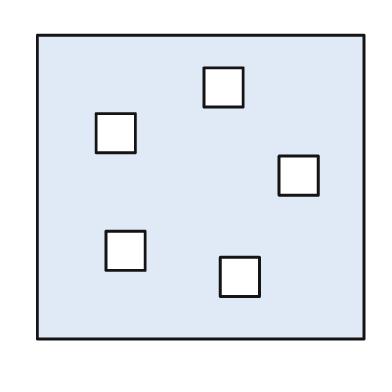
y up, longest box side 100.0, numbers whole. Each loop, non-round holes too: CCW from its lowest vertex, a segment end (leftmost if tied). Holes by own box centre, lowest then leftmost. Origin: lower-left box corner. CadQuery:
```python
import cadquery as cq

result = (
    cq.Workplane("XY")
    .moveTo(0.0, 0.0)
    .lineTo(100.0, 0.0)
    .lineTo(100.0, 93.0)
    .lineTo(0.0, 93.0)
    .close()
    .moveTo(56.0, 13.0)
    .lineTo(68.0, 13.0)
    .lineTo(68.0, 25.0)
    .lineTo(56.0, 25.0)
    .close()
    .moveTo(21.0, 21.0)
    .lineTo(33.0, 21.0)
    .lineTo(33.0, 33.0)
    .lineTo(21.0, 33.0)
    .close()
    .moveTo(74.0, 44.0)
    .lineTo(86.0, 44.0)
    .lineTo(86.0, 56.0)
    .lineTo(74.0, 56.0)
    .close()
    .moveTo(18.0, 57.0)
    .lineTo(30.0, 57.0)
    .lineTo(30.0, 69.0)
    .lineTo(18.0, 69.0)
    .close()
    .moveTo(51.0, 71.0)
    .lineTo(63.0, 71.0)
    .lineTo(63.0, 83.0)
    .lineTo(51.0, 83.0)
    .close()
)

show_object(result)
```